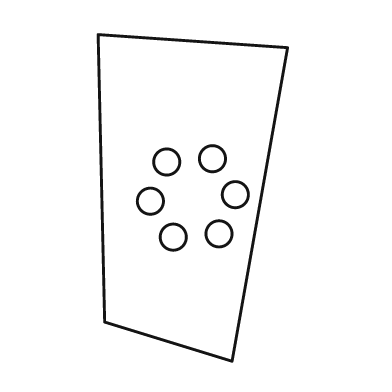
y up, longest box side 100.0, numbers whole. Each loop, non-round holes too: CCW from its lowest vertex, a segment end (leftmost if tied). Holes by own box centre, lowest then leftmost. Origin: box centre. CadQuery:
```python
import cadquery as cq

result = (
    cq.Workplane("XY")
    .moveTo(12.0, -50.0)
    .lineTo(29.0, 46.0)
    .lineTo(-29.0, 50.0)
    .lineTo(-27.0, -38.0)
    .close()
    .moveTo(-6.0, -12.0)
    .circle(4.0)
    .moveTo(8.0, -11.0)
    .circle(4.0)
    .moveTo(-13.0, -1.0)
    .circle(4.0)
    .moveTo(13.0, 1.0)
    .circle(4.0)
    .moveTo(-8.0, 11.0)
    .circle(4.0)
    .moveTo(6.0, 12.0)
    .circle(4.0)
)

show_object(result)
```